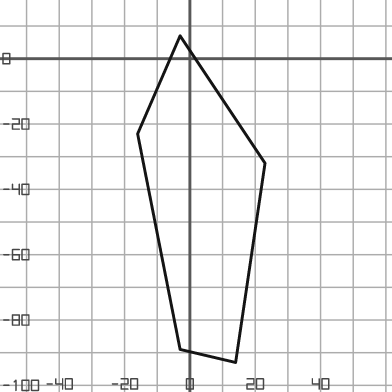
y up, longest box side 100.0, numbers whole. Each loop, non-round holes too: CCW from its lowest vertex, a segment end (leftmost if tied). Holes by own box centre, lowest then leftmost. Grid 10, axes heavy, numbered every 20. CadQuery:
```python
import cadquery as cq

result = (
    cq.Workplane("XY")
    .moveTo(14.0, -93.0)
    .lineTo(23.0, -32.0)
    .lineTo(-3.0, 7.0)
    .lineTo(-16.0, -23.0)
    .lineTo(-3.0, -89.0)
    .close()
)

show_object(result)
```